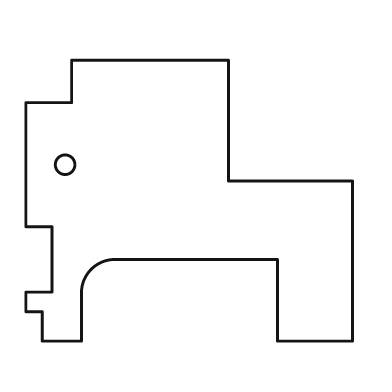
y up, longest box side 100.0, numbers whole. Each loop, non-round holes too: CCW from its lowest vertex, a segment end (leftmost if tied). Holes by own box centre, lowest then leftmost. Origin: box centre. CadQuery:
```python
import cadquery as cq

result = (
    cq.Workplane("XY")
    .moveTo(-45.0, -43.0)
    .lineTo(-33.0, -43.0)
    .lineTo(-33.0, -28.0)
    .threePointArc((-30.0, -21.0), (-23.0, -18.0))
    .lineTo(27.0, -18.0)
    .lineTo(27.0, -43.0)
    .lineTo(50.0, -43.0)
    .lineTo(50.0, 6.0)
    .lineTo(12.0, 6.0)
    .lineTo(12.0, 43.0)
    .lineTo(-36.0, 43.0)
    .lineTo(-36.0, 30.0)
    .lineTo(-50.0, 30.0)
    .lineTo(-50.0, -8.0)
    .lineTo(-42.0, -8.0)
    .lineTo(-42.0, -28.0)
    .lineTo(-50.0, -28.0)
    .lineTo(-50.0, -34.0)
    .lineTo(-45.0, -34.0)
    .close()
    .moveTo(-38.0, 11.0)
    .circle(3.0)
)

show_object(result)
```